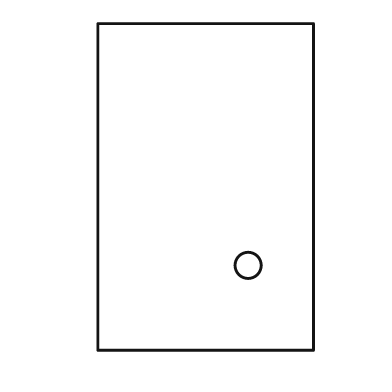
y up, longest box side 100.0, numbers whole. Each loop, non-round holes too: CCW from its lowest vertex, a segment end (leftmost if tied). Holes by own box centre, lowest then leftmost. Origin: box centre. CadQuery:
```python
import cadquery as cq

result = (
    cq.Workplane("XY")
    .moveTo(-33.0, -50.0)
    .lineTo(33.0, -50.0)
    .lineTo(33.0, 50.0)
    .lineTo(-33.0, 50.0)
    .close()
    .moveTo(13.0, -24.0)
    .circle(4.0)
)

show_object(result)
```